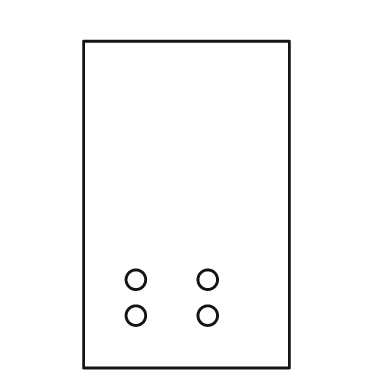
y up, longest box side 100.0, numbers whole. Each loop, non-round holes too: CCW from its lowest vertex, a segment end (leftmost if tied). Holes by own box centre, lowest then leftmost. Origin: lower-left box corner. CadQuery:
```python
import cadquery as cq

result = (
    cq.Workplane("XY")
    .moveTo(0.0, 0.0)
    .lineTo(63.0, 0.0)
    .lineTo(63.0, 100.0)
    .lineTo(0.0, 100.0)
    .close()
    .moveTo(16.0, 16.0)
    .circle(3.0)
    .moveTo(38.0, 16.0)
    .circle(3.0)
    .moveTo(16.0, 27.0)
    .circle(3.0)
    .moveTo(38.0, 27.0)
    .circle(3.0)
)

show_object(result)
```